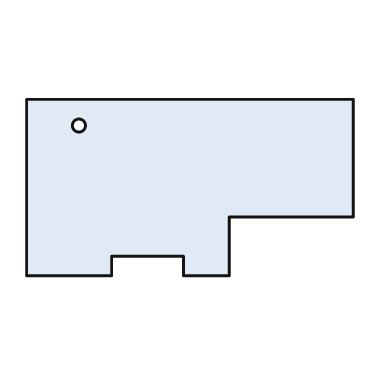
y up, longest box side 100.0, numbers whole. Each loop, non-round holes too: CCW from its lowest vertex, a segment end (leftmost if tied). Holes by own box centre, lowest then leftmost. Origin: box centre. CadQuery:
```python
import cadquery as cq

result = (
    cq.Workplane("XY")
    .moveTo(-50.0, -27.0)
    .lineTo(-24.0, -27.0)
    .lineTo(-24.0, -21.0)
    .lineTo(-2.0, -21.0)
    .lineTo(-2.0, -27.0)
    .lineTo(12.0, -27.0)
    .lineTo(12.0, -9.0)
    .lineTo(50.0, -9.0)
    .lineTo(50.0, 27.0)
    .lineTo(-50.0, 27.0)
    .close()
    .moveTo(-34.0, 19.0)
    .circle(2.0)
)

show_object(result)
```